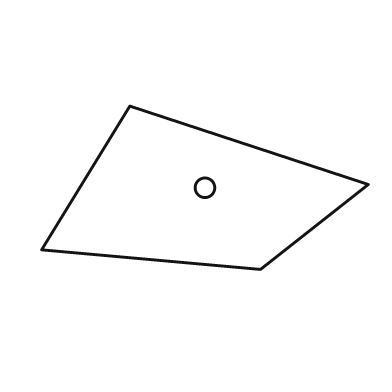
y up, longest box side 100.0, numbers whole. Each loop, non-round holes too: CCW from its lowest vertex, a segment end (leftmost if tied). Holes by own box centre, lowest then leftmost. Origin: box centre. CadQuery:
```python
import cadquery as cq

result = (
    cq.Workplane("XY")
    .moveTo(17.0, -25.0)
    .lineTo(50.0, 1.0)
    .lineTo(-23.0, 25.0)
    .lineTo(-50.0, -19.0)
    .close()
    .moveTo(0.0, 0.0)
    .circle(3.0)
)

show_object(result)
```